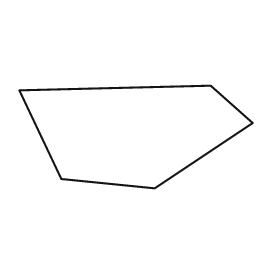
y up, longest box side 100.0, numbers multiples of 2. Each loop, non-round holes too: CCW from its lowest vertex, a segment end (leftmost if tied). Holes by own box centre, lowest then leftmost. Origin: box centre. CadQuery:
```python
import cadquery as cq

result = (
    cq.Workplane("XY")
    .moveTo(8.0, -22.0)
    .lineTo(50.0, 6.0)
    .lineTo(32.0, 22.0)
    .lineTo(-50.0, 20.0)
    .lineTo(-32.0, -18.0)
    .close()
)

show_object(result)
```